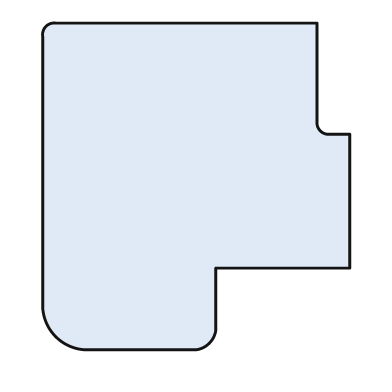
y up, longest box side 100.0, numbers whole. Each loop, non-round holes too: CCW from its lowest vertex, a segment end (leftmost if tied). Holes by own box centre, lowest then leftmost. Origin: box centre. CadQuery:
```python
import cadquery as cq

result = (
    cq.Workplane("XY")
    .moveTo(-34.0, -50.0)
    .lineTo(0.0, -50.0)
    .threePointArc((4.0, -48.0), (6.0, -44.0))
    .lineTo(6.0, -25.0)
    .lineTo(47.0, -25.0)
    .lineTo(47.0, 16.0)
    .lineTo(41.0, 16.0)
    .threePointArc((38.0, 17.0), (37.0, 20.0))
    .lineTo(37.0, 50.0)
    .lineTo(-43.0, 50.0)
    .threePointArc((-46.0, 49.0), (-47.0, 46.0))
    .lineTo(-47.0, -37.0)
    .threePointArc((-43.0, -46.0), (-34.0, -50.0))
    .close()
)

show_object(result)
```